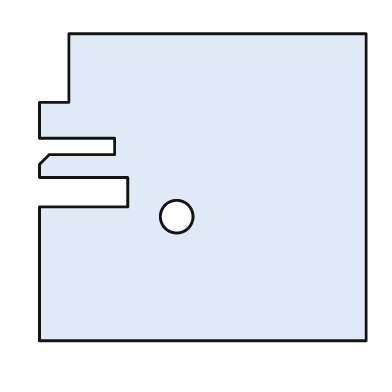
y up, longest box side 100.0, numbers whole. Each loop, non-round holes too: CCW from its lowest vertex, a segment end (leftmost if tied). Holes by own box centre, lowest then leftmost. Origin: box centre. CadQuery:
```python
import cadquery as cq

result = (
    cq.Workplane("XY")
    .moveTo(-50.0, -47.0)
    .lineTo(50.0, -47.0)
    .lineTo(50.0, 47.0)
    .lineTo(-41.0, 47.0)
    .lineTo(-41.0, 26.0)
    .lineTo(-50.0, 26.0)
    .lineTo(-50.0, 15.0)
    .lineTo(-27.0, 15.0)
    .lineTo(-27.0, 10.0)
    .lineTo(-47.0, 10.0)
    .lineTo(-50.0, 7.0)
    .lineTo(-50.0, 3.0)
    .lineTo(-23.0, 3.0)
    .lineTo(-23.0, -6.0)
    .lineTo(-50.0, -6.0)
    .close()
    .moveTo(-8.0, -9.0)
    .circle(5.0)
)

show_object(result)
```